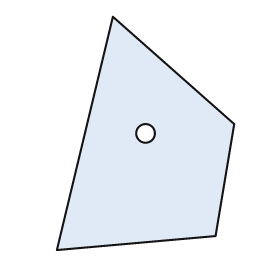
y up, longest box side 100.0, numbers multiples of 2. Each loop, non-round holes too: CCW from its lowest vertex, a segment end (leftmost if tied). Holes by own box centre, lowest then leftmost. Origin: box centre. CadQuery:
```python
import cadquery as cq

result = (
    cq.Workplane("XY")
    .moveTo(-38.0, -50.0)
    .lineTo(30.0, -44.0)
    .lineTo(38.0, 4.0)
    .lineTo(-14.0, 50.0)
    .close()
    .moveTo(0.0, 0.0)
    .circle(4.0)
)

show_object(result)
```